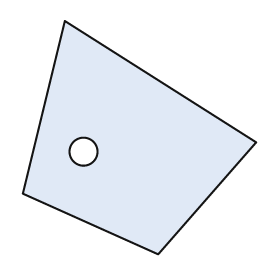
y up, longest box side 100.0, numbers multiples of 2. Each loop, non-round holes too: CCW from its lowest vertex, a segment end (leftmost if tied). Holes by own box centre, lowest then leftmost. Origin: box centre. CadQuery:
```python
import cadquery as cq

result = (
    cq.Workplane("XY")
    .moveTo(8.0, -50.0)
    .lineTo(50.0, -2.0)
    .lineTo(-32.0, 50.0)
    .lineTo(-50.0, -24.0)
    .close()
    .moveTo(-24.0, -6.0)
    .circle(6.0)
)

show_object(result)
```